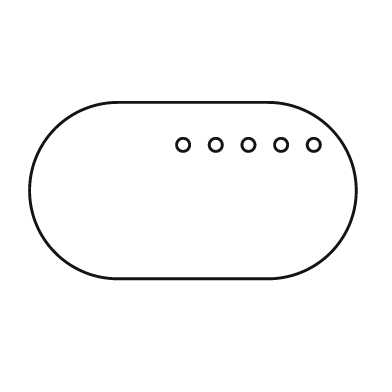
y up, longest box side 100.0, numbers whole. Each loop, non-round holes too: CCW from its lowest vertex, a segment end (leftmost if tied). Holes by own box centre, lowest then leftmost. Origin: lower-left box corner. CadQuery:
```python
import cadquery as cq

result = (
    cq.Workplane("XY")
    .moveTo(27.0, 0.0)
    .lineTo(73.0, 0.0)
    .threePointArc((100.0, 27.0), (73.0, 54.0))
    .lineTo(27.0, 54.0)
    .threePointArc((0.0, 27.0), (27.0, 0.0))
    .close()
    .moveTo(47.0, 41.0)
    .circle(2.0)
    .moveTo(57.0, 41.0)
    .circle(2.0)
    .moveTo(67.0, 41.0)
    .circle(2.0)
    .moveTo(77.0, 41.0)
    .circle(2.0)
    .moveTo(87.0, 41.0)
    .circle(2.0)
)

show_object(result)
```